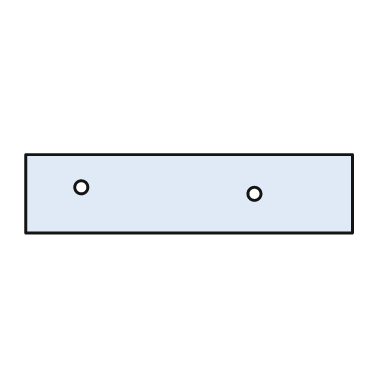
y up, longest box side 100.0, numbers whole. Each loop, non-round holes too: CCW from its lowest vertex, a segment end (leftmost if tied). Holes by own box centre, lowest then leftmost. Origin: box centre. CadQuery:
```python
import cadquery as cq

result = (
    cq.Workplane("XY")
    .moveTo(-50.0, -12.0)
    .lineTo(50.0, -12.0)
    .lineTo(50.0, 12.0)
    .lineTo(-50.0, 12.0)
    .close()
    .moveTo(20.0, 0.0)
    .circle(2.0)
    .moveTo(-33.0, 2.0)
    .circle(2.0)
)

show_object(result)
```